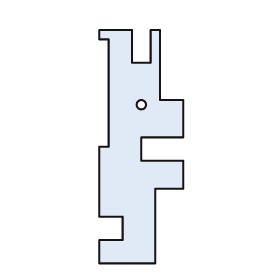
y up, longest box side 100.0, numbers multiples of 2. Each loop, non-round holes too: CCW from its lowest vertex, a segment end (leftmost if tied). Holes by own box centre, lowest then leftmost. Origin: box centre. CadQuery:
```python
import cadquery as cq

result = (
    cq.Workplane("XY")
    .moveTo(-18.0, -50.0)
    .lineTo(6.0, -50.0)
    .lineTo(6.0, -18.0)
    .lineTo(18.0, -18.0)
    .lineTo(18.0, -6.0)
    .lineTo(0.0, -6.0)
    .lineTo(0.0, 4.0)
    .lineTo(18.0, 4.0)
    .lineTo(18.0, 20.0)
    .lineTo(8.0, 20.0)
    .lineTo(8.0, 50.0)
    .lineTo(4.0, 50.0)
    .lineTo(4.0, 36.0)
    .lineTo(-4.0, 36.0)
    .lineTo(-4.0, 50.0)
    .lineTo(-18.0, 50.0)
    .lineTo(-18.0, 46.0)
    .lineTo(-14.0, 46.0)
    .lineTo(-14.0, 0.0)
    .lineTo(-18.0, 0.0)
    .lineTo(-18.0, -30.0)
    .lineTo(-8.0, -30.0)
    .lineTo(-8.0, -40.0)
    .lineTo(-18.0, -40.0)
    .close()
    .moveTo(0.0, 18.0)
    .circle(2.0)
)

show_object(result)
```